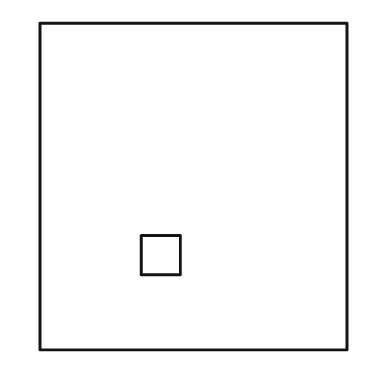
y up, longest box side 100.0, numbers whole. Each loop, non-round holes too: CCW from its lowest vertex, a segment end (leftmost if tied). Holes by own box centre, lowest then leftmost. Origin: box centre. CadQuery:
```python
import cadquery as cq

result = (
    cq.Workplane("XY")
    .moveTo(-47.0, -50.0)
    .lineTo(47.0, -50.0)
    .lineTo(47.0, 50.0)
    .lineTo(-47.0, 50.0)
    .close()
    .moveTo(-16.0, -27.0)
    .lineTo(-4.0, -27.0)
    .lineTo(-4.0, -15.0)
    .lineTo(-16.0, -15.0)
    .close()
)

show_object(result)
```